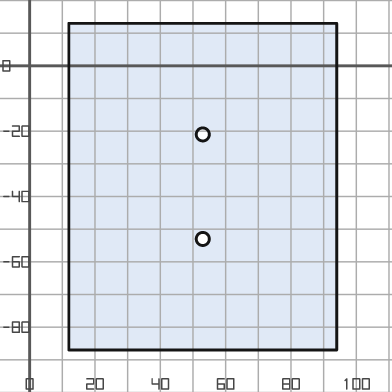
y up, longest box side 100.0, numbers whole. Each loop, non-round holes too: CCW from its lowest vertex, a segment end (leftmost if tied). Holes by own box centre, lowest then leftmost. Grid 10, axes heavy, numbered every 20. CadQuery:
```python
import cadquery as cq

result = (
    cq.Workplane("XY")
    .moveTo(12.0, -87.0)
    .lineTo(94.0, -87.0)
    .lineTo(94.0, 13.0)
    .lineTo(12.0, 13.0)
    .close()
    .moveTo(53.0, -53.0)
    .circle(2.0)
    .moveTo(53.0, -21.0)
    .circle(2.0)
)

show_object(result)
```